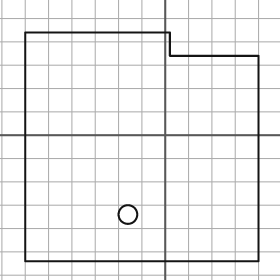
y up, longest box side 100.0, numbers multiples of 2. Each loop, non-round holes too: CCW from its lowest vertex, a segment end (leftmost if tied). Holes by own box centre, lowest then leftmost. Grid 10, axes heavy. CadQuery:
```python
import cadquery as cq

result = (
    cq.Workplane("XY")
    .moveTo(-60.0, -54.0)
    .lineTo(40.0, -54.0)
    .lineTo(40.0, 34.0)
    .lineTo(2.0, 34.0)
    .lineTo(2.0, 44.0)
    .lineTo(-60.0, 44.0)
    .close()
    .moveTo(-16.0, -34.0)
    .circle(4.0)
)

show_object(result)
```